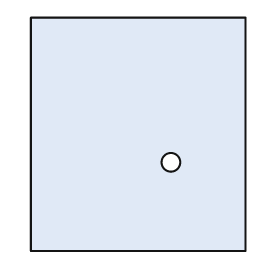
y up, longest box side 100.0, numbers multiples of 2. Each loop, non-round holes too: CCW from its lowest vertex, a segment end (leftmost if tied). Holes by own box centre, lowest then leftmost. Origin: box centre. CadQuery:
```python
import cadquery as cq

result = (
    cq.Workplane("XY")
    .moveTo(-46.0, -50.0)
    .lineTo(46.0, -50.0)
    .lineTo(46.0, 50.0)
    .lineTo(-46.0, 50.0)
    .close()
    .moveTo(14.0, -12.0)
    .circle(4.0)
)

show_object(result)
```